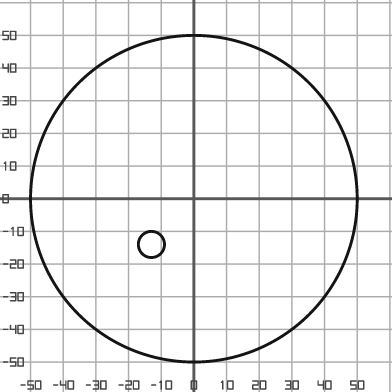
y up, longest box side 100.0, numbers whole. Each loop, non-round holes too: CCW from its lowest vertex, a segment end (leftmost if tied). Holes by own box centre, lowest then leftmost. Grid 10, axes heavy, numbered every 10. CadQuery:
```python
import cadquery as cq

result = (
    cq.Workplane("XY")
    .moveTo(0.0, 0.0)
    .circle(50.0)
    .moveTo(-13.0, -14.0)
    .circle(4.0)
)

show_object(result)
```